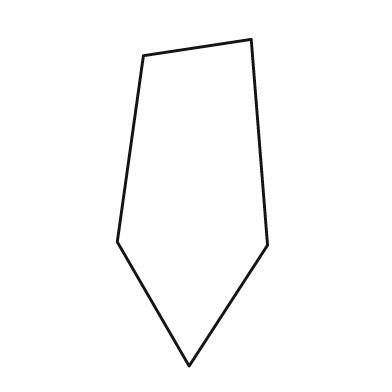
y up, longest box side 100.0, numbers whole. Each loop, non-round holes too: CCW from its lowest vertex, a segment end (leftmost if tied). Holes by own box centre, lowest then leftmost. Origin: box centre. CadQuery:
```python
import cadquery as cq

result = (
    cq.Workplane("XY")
    .moveTo(-1.0, -50.0)
    .lineTo(23.0, -13.0)
    .lineTo(18.0, 50.0)
    .lineTo(-15.0, 45.0)
    .lineTo(-23.0, -12.0)
    .close()
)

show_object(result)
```